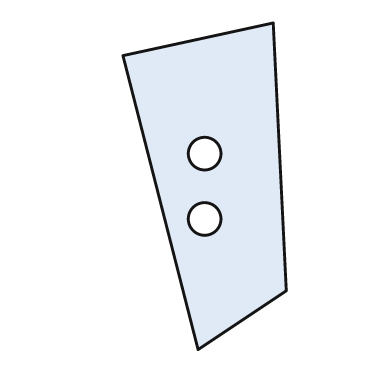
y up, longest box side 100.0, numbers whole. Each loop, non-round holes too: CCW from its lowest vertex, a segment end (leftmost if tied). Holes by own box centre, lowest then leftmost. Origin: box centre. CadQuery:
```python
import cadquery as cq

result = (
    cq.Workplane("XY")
    .moveTo(-2.0, -50.0)
    .lineTo(25.0, -32.0)
    .lineTo(21.0, 50.0)
    .lineTo(-25.0, 40.0)
    .close()
    .moveTo(0.0, -10.0)
    .circle(5.0)
    .moveTo(0.0, 10.0)
    .circle(5.0)
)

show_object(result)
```